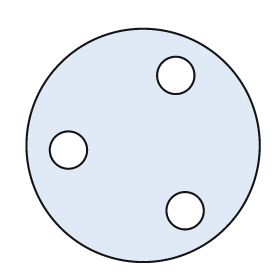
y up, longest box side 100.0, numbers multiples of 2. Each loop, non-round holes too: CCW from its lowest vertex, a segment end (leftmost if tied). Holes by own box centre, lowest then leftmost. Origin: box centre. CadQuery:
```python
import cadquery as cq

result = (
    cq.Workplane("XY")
    .moveTo(0.0, 0.0)
    .circle(50.0)
    .moveTo(18.0, -28.0)
    .circle(8.0)
    .moveTo(-32.0, -2.0)
    .circle(8.0)
    .moveTo(14.0, 30.0)
    .circle(8.0)
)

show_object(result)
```